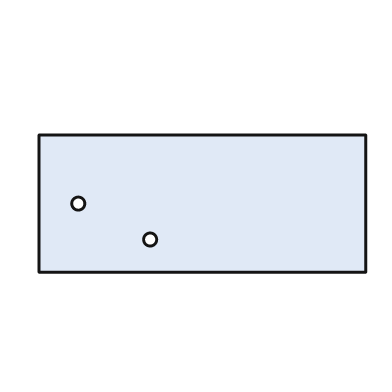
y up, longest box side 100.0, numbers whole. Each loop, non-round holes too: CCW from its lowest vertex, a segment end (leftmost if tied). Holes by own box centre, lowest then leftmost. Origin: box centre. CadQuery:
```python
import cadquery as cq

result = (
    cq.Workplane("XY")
    .moveTo(-50.0, -21.0)
    .lineTo(50.0, -21.0)
    .lineTo(50.0, 21.0)
    .lineTo(-50.0, 21.0)
    .close()
    .moveTo(-16.0, -11.0)
    .circle(2.0)
    .moveTo(-38.0, 0.0)
    .circle(2.0)
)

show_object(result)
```